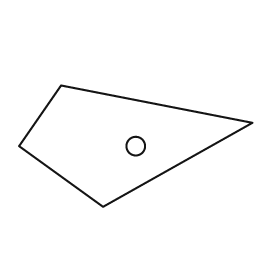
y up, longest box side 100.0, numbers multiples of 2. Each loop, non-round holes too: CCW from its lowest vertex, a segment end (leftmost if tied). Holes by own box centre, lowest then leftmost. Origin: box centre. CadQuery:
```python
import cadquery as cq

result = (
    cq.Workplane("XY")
    .moveTo(-14.0, -26.0)
    .lineTo(50.0, 10.0)
    .lineTo(-32.0, 26.0)
    .lineTo(-50.0, 0.0)
    .close()
    .moveTo(0.0, 0.0)
    .circle(4.0)
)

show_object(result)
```